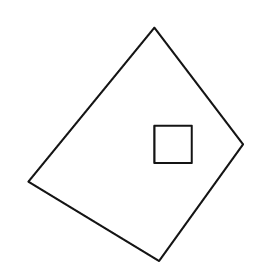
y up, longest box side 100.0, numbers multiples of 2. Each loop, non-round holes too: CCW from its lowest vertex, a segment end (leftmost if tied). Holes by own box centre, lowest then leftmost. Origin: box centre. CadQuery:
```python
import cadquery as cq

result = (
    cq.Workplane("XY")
    .moveTo(10.0, -50.0)
    .lineTo(46.0, 0.0)
    .lineTo(8.0, 50.0)
    .lineTo(-46.0, -16.0)
    .close()
    .moveTo(8.0, -8.0)
    .lineTo(24.0, -8.0)
    .lineTo(24.0, 8.0)
    .lineTo(8.0, 8.0)
    .close()
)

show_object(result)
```